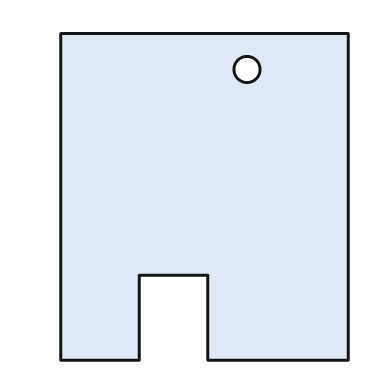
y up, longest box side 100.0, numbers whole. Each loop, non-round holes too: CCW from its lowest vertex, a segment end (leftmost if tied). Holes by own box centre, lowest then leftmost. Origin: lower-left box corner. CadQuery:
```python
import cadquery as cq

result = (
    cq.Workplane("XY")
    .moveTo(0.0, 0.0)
    .lineTo(24.0, 0.0)
    .lineTo(24.0, 26.0)
    .lineTo(45.0, 26.0)
    .lineTo(45.0, 0.0)
    .lineTo(88.0, 0.0)
    .lineTo(88.0, 100.0)
    .lineTo(0.0, 100.0)
    .close()
    .moveTo(57.0, 89.0)
    .circle(4.0)
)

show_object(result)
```